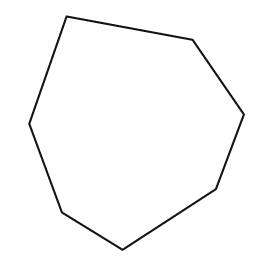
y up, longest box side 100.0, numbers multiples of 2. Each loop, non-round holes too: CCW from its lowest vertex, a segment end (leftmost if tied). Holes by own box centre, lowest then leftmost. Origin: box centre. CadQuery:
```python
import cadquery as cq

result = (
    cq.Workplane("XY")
    .moveTo(-6.0, -50.0)
    .lineTo(34.0, -24.0)
    .lineTo(46.0, 8.0)
    .lineTo(24.0, 40.0)
    .lineTo(-30.0, 50.0)
    .lineTo(-46.0, 4.0)
    .lineTo(-32.0, -34.0)
    .close()
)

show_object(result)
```